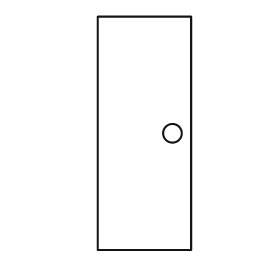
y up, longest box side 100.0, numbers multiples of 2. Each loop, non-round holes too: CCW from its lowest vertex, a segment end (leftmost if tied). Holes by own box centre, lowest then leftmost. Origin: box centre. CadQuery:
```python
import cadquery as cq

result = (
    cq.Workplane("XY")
    .moveTo(-20.0, -50.0)
    .lineTo(20.0, -50.0)
    .lineTo(20.0, 50.0)
    .lineTo(-20.0, 50.0)
    .close()
    .moveTo(12.0, 0.0)
    .circle(4.0)
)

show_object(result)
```